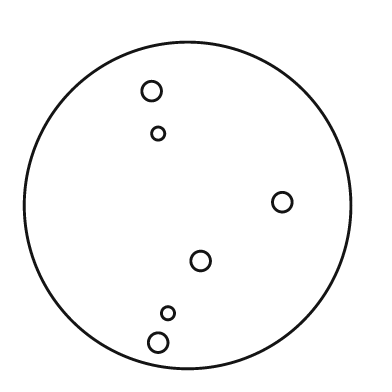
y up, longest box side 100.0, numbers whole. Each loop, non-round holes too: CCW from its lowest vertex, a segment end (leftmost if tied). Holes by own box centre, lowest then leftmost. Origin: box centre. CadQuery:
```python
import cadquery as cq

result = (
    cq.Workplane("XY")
    .moveTo(0.0, 0.0)
    .circle(50.0)
    .moveTo(-9.0, -42.0)
    .circle(3.0)
    .moveTo(-6.0, -33.0)
    .circle(2.0)
    .moveTo(4.0, -17.0)
    .circle(3.0)
    .moveTo(29.0, 1.0)
    .circle(3.0)
    .moveTo(-9.0, 22.0)
    .circle(2.0)
    .moveTo(-11.0, 35.0)
    .circle(3.0)
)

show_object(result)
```